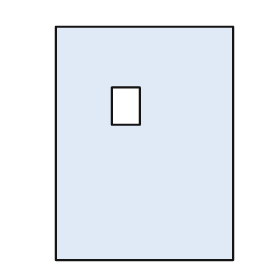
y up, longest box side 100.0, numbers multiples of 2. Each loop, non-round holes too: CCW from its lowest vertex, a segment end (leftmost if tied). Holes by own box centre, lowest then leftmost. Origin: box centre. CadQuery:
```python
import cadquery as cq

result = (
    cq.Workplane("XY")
    .moveTo(-38.0, -50.0)
    .lineTo(38.0, -50.0)
    .lineTo(38.0, 50.0)
    .lineTo(-38.0, 50.0)
    .close()
    .moveTo(-14.0, 8.0)
    .lineTo(-2.0, 8.0)
    .lineTo(-2.0, 24.0)
    .lineTo(-14.0, 24.0)
    .close()
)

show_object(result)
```